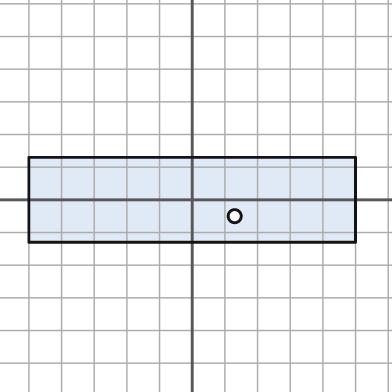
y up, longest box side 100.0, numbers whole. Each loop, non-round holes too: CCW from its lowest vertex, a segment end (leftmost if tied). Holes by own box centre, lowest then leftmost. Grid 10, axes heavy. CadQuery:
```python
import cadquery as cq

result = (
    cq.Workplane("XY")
    .moveTo(-50.0, -13.0)
    .lineTo(50.0, -13.0)
    .lineTo(50.0, 13.0)
    .lineTo(-50.0, 13.0)
    .close()
    .moveTo(13.0, -5.0)
    .circle(2.0)
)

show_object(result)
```